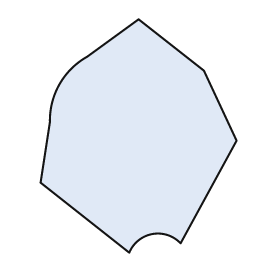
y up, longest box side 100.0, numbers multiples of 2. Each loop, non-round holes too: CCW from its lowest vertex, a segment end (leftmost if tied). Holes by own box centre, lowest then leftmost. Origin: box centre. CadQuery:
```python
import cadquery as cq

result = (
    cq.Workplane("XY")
    .moveTo(-4.0, -50.0)
    .threePointArc((6.0, -42.0), (18.0, -46.0))
    .lineTo(42.0, -2.0)
    .lineTo(28.0, 28.0)
    .lineTo(0.0, 50.0)
    .lineTo(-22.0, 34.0)
    .threePointArc((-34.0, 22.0), (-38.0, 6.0))
    .lineTo(-42.0, -20.0)
    .close()
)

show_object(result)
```